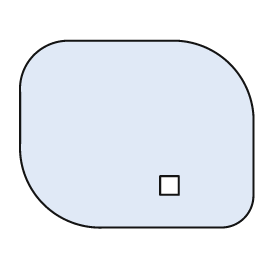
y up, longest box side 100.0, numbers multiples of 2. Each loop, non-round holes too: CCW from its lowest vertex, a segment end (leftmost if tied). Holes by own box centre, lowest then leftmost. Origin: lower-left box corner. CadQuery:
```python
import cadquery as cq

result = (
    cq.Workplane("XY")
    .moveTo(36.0, 0.0)
    .lineTo(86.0, 0.0)
    .threePointArc((96.0, 4.0), (100.0, 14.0))
    .lineTo(100.0, 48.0)
    .threePointArc((90.0, 70.0), (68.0, 80.0))
    .lineTo(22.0, 80.0)
    .threePointArc((6.0, 74.0), (0.0, 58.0))
    .lineTo(0.0, 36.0)
    .threePointArc((10.0, 10.0), (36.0, 0.0))
    .close()
    .moveTo(60.0, 14.0)
    .lineTo(68.0, 14.0)
    .lineTo(68.0, 22.0)
    .lineTo(60.0, 22.0)
    .close()
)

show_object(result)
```